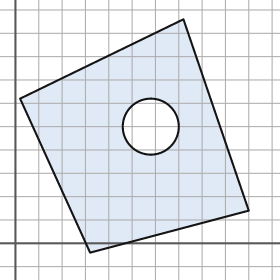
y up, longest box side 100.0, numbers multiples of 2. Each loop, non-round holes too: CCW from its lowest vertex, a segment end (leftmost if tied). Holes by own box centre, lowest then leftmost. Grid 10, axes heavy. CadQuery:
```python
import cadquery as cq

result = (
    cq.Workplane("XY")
    .moveTo(32.0, -4.0)
    .lineTo(100.0, 14.0)
    .lineTo(72.0, 96.0)
    .lineTo(2.0, 62.0)
    .close()
    .moveTo(58.0, 50.0)
    .circle(12.0)
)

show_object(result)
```